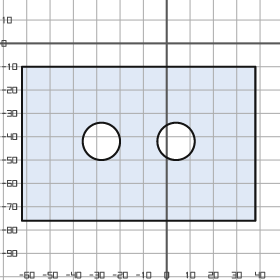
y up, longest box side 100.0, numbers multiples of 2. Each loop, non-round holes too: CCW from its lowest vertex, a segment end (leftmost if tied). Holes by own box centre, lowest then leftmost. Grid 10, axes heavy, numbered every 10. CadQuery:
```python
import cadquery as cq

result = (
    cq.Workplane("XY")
    .moveTo(-62.0, -76.0)
    .lineTo(38.0, -76.0)
    .lineTo(38.0, -10.0)
    .lineTo(-62.0, -10.0)
    .close()
    .moveTo(-28.0, -42.0)
    .circle(8.0)
    .moveTo(4.0, -42.0)
    .circle(8.0)
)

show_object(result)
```